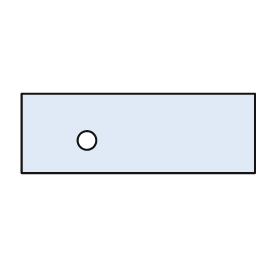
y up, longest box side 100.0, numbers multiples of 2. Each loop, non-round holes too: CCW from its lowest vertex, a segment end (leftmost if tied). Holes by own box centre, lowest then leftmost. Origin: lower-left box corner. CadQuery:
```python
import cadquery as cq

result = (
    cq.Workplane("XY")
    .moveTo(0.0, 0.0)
    .lineTo(100.0, 0.0)
    .lineTo(100.0, 34.0)
    .lineTo(0.0, 34.0)
    .close()
    .moveTo(28.0, 14.0)
    .circle(4.0)
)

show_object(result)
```